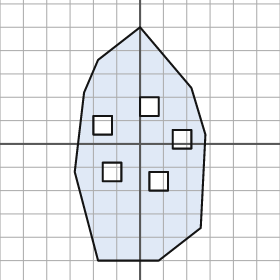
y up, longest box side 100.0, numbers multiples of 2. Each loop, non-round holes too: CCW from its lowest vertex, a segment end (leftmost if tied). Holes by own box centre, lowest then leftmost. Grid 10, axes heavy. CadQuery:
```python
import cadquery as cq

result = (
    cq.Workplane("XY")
    .moveTo(-18.0, -50.0)
    .lineTo(8.0, -50.0)
    .lineTo(26.0, -36.0)
    .lineTo(28.0, 4.0)
    .lineTo(22.0, 24.0)
    .lineTo(0.0, 50.0)
    .lineTo(-18.0, 36.0)
    .lineTo(-24.0, 22.0)
    .lineTo(-28.0, -12.0)
    .close()
    .moveTo(4.0, -20.0)
    .lineTo(12.0, -20.0)
    .lineTo(12.0, -12.0)
    .lineTo(4.0, -12.0)
    .close()
    .moveTo(-16.0, -16.0)
    .lineTo(-8.0, -16.0)
    .lineTo(-8.0, -8.0)
    .lineTo(-16.0, -8.0)
    .close()
    .moveTo(14.0, -2.0)
    .lineTo(22.0, -2.0)
    .lineTo(22.0, 6.0)
    .lineTo(14.0, 6.0)
    .close()
    .moveTo(-20.0, 4.0)
    .lineTo(-12.0, 4.0)
    .lineTo(-12.0, 12.0)
    .lineTo(-20.0, 12.0)
    .close()
    .moveTo(0.0, 12.0)
    .lineTo(8.0, 12.0)
    .lineTo(8.0, 20.0)
    .lineTo(0.0, 20.0)
    .close()
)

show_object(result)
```